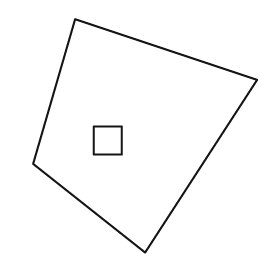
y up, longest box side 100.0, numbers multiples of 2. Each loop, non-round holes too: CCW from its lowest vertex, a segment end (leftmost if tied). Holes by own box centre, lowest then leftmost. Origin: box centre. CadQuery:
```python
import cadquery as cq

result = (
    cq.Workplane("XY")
    .moveTo(0.0, -50.0)
    .lineTo(48.0, 24.0)
    .lineTo(-30.0, 50.0)
    .lineTo(-48.0, -12.0)
    .close()
    .moveTo(-22.0, -8.0)
    .lineTo(-10.0, -8.0)
    .lineTo(-10.0, 4.0)
    .lineTo(-22.0, 4.0)
    .close()
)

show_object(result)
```